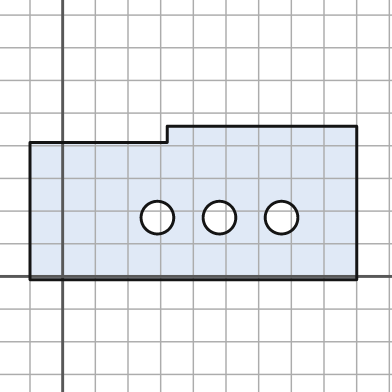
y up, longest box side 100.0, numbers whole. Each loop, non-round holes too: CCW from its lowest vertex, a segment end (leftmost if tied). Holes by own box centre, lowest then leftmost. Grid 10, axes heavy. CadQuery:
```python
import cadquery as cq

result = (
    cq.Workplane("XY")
    .moveTo(-10.0, -1.0)
    .lineTo(90.0, -1.0)
    .lineTo(90.0, 46.0)
    .lineTo(32.0, 46.0)
    .lineTo(32.0, 41.0)
    .lineTo(-10.0, 41.0)
    .close()
    .moveTo(29.0, 18.0)
    .circle(5.0)
    .moveTo(48.0, 18.0)
    .circle(5.0)
    .moveTo(67.0, 18.0)
    .circle(5.0)
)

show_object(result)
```